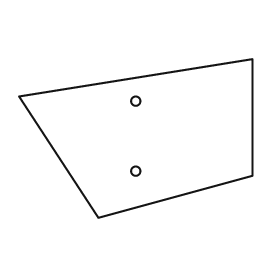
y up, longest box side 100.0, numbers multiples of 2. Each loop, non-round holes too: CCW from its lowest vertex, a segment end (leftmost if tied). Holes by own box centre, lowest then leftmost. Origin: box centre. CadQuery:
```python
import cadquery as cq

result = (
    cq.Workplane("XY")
    .moveTo(-16.0, -34.0)
    .lineTo(50.0, -16.0)
    .lineTo(50.0, 34.0)
    .lineTo(-50.0, 18.0)
    .close()
    .moveTo(0.0, -14.0)
    .circle(2.0)
    .moveTo(0.0, 16.0)
    .circle(2.0)
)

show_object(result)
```